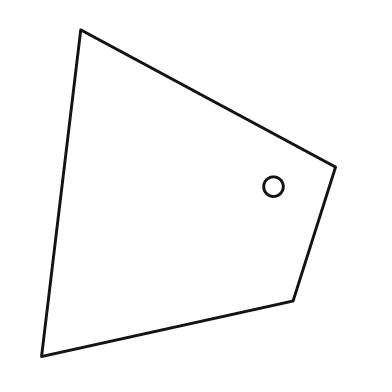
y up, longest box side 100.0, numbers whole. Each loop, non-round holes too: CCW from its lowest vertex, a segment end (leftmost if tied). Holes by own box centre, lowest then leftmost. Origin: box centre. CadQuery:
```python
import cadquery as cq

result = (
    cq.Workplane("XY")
    .moveTo(-45.0, -50.0)
    .lineTo(32.0, -33.0)
    .lineTo(45.0, 8.0)
    .lineTo(-33.0, 50.0)
    .close()
    .moveTo(26.0, 2.0)
    .circle(3.0)
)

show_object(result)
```